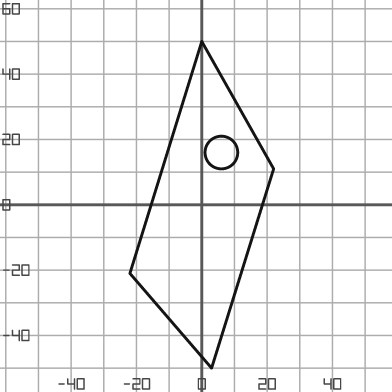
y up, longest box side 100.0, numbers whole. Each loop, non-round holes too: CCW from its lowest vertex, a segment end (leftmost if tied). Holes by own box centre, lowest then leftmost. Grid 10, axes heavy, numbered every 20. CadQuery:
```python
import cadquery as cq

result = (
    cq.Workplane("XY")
    .moveTo(3.0, -50.0)
    .lineTo(22.0, 11.0)
    .lineTo(0.0, 50.0)
    .lineTo(-22.0, -21.0)
    .close()
    .moveTo(6.0, 16.0)
    .circle(5.0)
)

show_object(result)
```